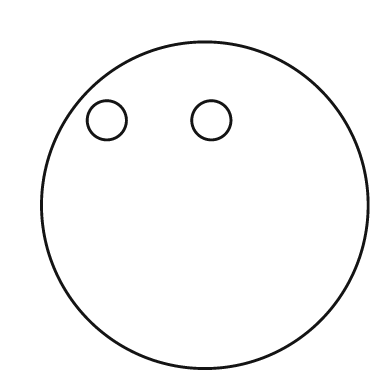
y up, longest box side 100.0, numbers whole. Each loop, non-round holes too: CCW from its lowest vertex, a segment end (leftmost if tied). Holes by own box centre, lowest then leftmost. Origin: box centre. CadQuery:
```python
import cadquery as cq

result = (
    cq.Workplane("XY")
    .moveTo(0.0, 0.0)
    .circle(50.0)
    .moveTo(-30.0, 26.0)
    .circle(6.0)
    .moveTo(2.0, 26.0)
    .circle(6.0)
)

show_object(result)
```